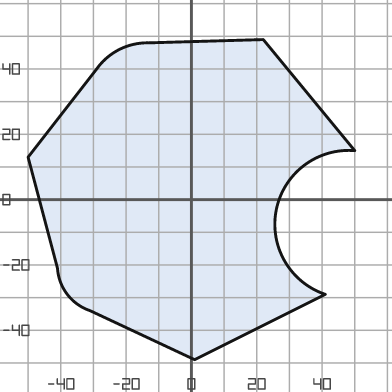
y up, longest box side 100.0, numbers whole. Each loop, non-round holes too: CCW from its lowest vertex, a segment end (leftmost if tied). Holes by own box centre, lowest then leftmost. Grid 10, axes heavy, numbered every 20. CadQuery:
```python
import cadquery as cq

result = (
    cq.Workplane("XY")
    .moveTo(1.0, -49.0)
    .lineTo(41.0, -29.0)
    .threePointArc((26.0, -3.0), (50.0, 15.0))
    .lineTo(22.0, 49.0)
    .lineTo(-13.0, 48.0)
    .threePointArc((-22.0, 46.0), (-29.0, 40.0))
    .lineTo(-50.0, 13.0)
    .lineTo(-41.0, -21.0)
    .threePointArc((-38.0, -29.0), (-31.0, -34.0))
    .close()
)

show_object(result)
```